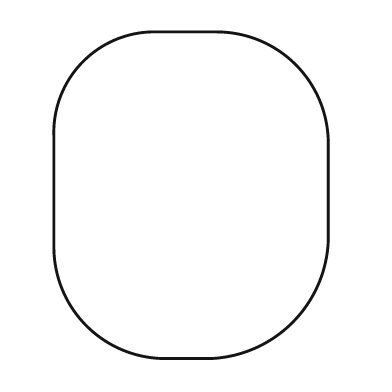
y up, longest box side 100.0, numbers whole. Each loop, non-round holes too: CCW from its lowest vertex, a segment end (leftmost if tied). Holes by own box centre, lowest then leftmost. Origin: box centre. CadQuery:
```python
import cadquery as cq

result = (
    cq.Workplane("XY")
    .moveTo(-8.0, -50.0)
    .lineTo(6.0, -50.0)
    .threePointArc((31.0, -39.0), (42.0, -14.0))
    .lineTo(42.0, 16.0)
    .threePointArc((32.0, 40.0), (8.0, 50.0))
    .lineTo(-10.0, 50.0)
    .threePointArc((-33.0, 41.0), (-42.0, 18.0))
    .lineTo(-42.0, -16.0)
    .threePointArc((-32.0, -40.0), (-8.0, -50.0))
    .close()
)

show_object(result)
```